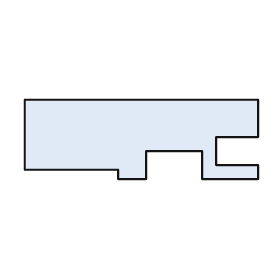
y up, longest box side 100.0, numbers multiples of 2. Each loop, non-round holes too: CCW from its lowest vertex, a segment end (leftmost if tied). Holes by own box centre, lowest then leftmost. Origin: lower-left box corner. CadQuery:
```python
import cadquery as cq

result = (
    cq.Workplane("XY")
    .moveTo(40.0, 0.0)
    .lineTo(52.0, 0.0)
    .lineTo(52.0, 12.0)
    .lineTo(76.0, 12.0)
    .lineTo(76.0, 0.0)
    .lineTo(100.0, 0.0)
    .lineTo(100.0, 6.0)
    .lineTo(82.0, 6.0)
    .lineTo(82.0, 18.0)
    .lineTo(100.0, 18.0)
    .lineTo(100.0, 34.0)
    .lineTo(0.0, 34.0)
    .lineTo(0.0, 4.0)
    .lineTo(40.0, 4.0)
    .close()
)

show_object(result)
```